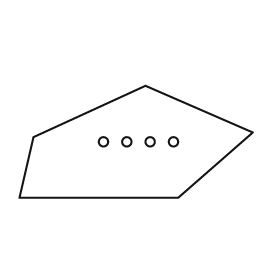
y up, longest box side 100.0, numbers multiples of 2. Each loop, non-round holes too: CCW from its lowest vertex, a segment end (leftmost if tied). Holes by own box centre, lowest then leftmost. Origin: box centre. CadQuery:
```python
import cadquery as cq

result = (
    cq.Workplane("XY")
    .moveTo(-50.0, -24.0)
    .lineTo(18.0, -24.0)
    .lineTo(50.0, 4.0)
    .lineTo(4.0, 24.0)
    .lineTo(-44.0, 2.0)
    .close()
    .moveTo(-14.0, 0.0)
    .circle(2.0)
    .moveTo(-4.0, 0.0)
    .circle(2.0)
    .moveTo(6.0, 0.0)
    .circle(2.0)
    .moveTo(16.0, 0.0)
    .circle(2.0)
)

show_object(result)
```